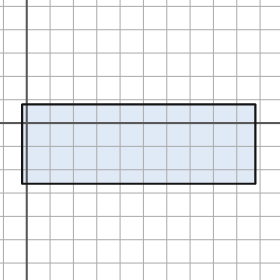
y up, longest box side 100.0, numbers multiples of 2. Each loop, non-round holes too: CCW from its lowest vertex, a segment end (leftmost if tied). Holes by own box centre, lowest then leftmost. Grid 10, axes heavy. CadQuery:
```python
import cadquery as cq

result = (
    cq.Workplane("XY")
    .moveTo(-2.0, -26.0)
    .lineTo(98.0, -26.0)
    .lineTo(98.0, 8.0)
    .lineTo(-2.0, 8.0)
    .close()
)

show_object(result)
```